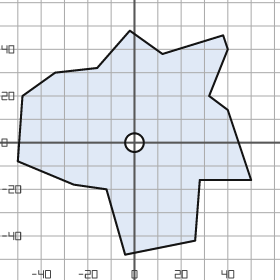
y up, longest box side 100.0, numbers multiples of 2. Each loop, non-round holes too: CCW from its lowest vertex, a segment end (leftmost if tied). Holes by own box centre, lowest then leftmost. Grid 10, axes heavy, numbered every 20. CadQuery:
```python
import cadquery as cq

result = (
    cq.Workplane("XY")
    .moveTo(-4.0, -48.0)
    .lineTo(26.0, -42.0)
    .lineTo(28.0, -16.0)
    .lineTo(50.0, -16.0)
    .lineTo(40.0, 14.0)
    .lineTo(32.0, 20.0)
    .lineTo(40.0, 40.0)
    .lineTo(38.0, 46.0)
    .lineTo(12.0, 38.0)
    .lineTo(-2.0, 48.0)
    .lineTo(-16.0, 32.0)
    .lineTo(-34.0, 30.0)
    .lineTo(-48.0, 20.0)
    .lineTo(-50.0, -8.0)
    .lineTo(-26.0, -18.0)
    .lineTo(-12.0, -20.0)
    .close()
    .moveTo(0.0, 0.0)
    .circle(4.0)
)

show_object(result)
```